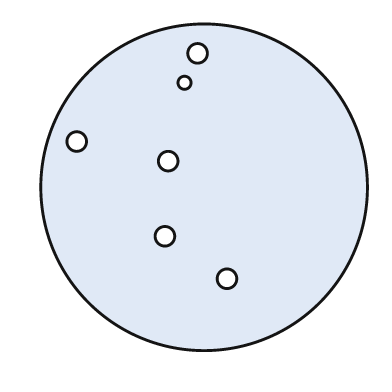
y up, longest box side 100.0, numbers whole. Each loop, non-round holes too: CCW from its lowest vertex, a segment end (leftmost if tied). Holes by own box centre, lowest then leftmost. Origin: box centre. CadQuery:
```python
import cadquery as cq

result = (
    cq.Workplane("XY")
    .moveTo(0.0, 0.0)
    .circle(50.0)
    .moveTo(7.0, -28.0)
    .circle(3.0)
    .moveTo(-12.0, -15.0)
    .circle(3.0)
    .moveTo(-11.0, 8.0)
    .circle(3.0)
    .moveTo(-39.0, 14.0)
    .circle(3.0)
    .moveTo(-6.0, 32.0)
    .circle(2.0)
    .moveTo(-2.0, 41.0)
    .circle(3.0)
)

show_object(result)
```